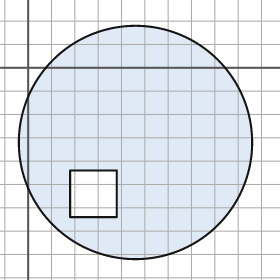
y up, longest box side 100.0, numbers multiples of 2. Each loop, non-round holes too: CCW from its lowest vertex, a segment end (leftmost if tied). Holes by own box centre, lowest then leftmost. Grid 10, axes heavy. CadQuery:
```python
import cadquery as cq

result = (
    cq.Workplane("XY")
    .moveTo(46.0, -32.0)
    .circle(50.0)
    .moveTo(18.0, -64.0)
    .lineTo(38.0, -64.0)
    .lineTo(38.0, -44.0)
    .lineTo(18.0, -44.0)
    .close()
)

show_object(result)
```